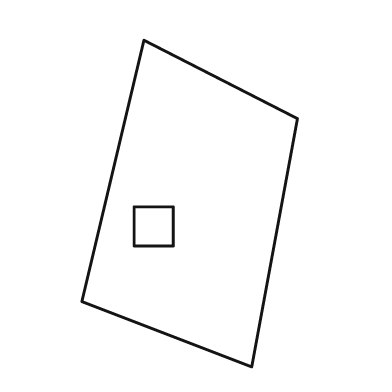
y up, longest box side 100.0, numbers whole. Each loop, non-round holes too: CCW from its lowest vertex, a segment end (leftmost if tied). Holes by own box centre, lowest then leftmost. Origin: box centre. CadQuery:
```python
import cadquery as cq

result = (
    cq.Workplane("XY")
    .moveTo(19.0, -50.0)
    .lineTo(33.0, 26.0)
    .lineTo(-14.0, 50.0)
    .lineTo(-33.0, -30.0)
    .close()
    .moveTo(-17.0, -13.0)
    .lineTo(-5.0, -13.0)
    .lineTo(-5.0, -1.0)
    .lineTo(-17.0, -1.0)
    .close()
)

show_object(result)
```